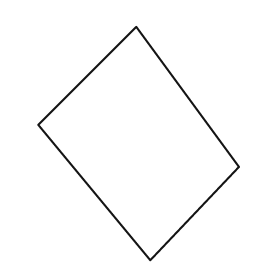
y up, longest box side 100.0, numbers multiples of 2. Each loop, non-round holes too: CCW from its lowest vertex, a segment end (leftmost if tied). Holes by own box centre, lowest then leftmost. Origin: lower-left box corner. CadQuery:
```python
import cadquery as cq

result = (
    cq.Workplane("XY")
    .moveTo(48.0, 0.0)
    .lineTo(86.0, 40.0)
    .lineTo(42.0, 100.0)
    .lineTo(0.0, 58.0)
    .close()
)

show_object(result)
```